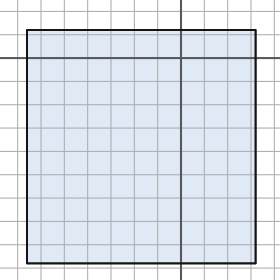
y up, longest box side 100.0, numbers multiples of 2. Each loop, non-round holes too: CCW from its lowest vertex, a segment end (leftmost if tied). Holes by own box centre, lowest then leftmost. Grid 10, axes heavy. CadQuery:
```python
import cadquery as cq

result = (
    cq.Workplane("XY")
    .moveTo(-66.0, -88.0)
    .lineTo(32.0, -88.0)
    .lineTo(32.0, 12.0)
    .lineTo(-66.0, 12.0)
    .close()
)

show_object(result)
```